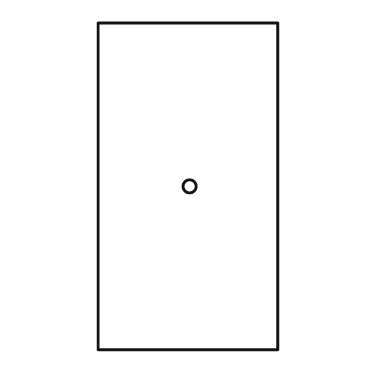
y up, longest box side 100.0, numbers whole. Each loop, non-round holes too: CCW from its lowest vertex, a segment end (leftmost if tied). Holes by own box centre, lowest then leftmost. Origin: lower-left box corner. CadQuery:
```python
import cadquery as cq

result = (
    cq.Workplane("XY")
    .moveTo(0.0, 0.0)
    .lineTo(55.0, 0.0)
    .lineTo(55.0, 100.0)
    .lineTo(0.0, 100.0)
    .close()
    .moveTo(28.0, 50.0)
    .circle(2.0)
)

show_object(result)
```